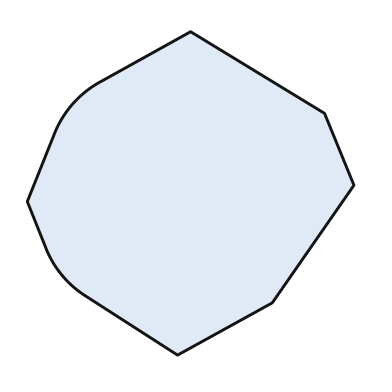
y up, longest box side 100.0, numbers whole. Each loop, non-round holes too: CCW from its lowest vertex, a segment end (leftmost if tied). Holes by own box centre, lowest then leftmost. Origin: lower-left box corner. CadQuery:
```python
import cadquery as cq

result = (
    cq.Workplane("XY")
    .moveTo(46.0, 0.0)
    .lineTo(75.0, 16.0)
    .lineTo(100.0, 52.0)
    .lineTo(91.0, 74.0)
    .lineTo(50.0, 99.0)
    .lineTo(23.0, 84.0)
    .threePointArc((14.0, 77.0), (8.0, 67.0))
    .lineTo(0.0, 47.0)
    .lineTo(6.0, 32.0)
    .threePointArc((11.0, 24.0), (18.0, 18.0))
    .close()
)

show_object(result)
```